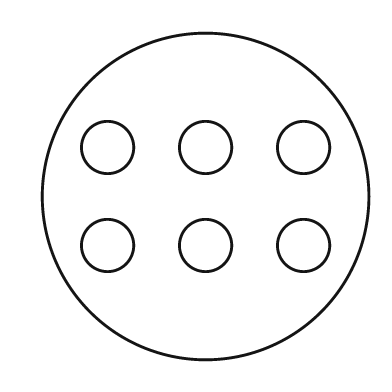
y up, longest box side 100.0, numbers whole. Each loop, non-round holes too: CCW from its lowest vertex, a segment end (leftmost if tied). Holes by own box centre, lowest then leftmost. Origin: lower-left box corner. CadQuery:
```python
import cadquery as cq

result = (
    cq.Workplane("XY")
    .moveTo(50.0, 50.0)
    .circle(50.0)
    .moveTo(20.0, 35.0)
    .circle(8.0)
    .moveTo(50.0, 35.0)
    .circle(8.0)
    .moveTo(80.0, 35.0)
    .circle(8.0)
    .moveTo(20.0, 65.0)
    .circle(8.0)
    .moveTo(50.0, 65.0)
    .circle(8.0)
    .moveTo(80.0, 65.0)
    .circle(8.0)
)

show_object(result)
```